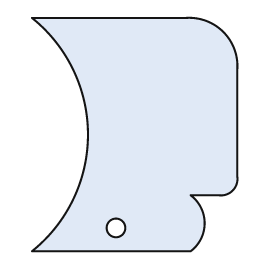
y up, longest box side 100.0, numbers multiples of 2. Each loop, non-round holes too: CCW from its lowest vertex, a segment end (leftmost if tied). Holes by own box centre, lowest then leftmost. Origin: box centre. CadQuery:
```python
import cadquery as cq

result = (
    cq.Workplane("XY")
    .moveTo(-44.0, -50.0)
    .lineTo(24.0, -50.0)
    .threePointArc((30.0, -38.0), (24.0, -26.0))
    .lineTo(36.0, -26.0)
    .threePointArc((42.0, -24.0), (44.0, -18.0))
    .lineTo(44.0, 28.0)
    .threePointArc((38.0, 44.0), (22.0, 50.0))
    .lineTo(-44.0, 50.0)
    .threePointArc((-20.0, 0.0), (-44.0, -50.0))
    .close()
    .moveTo(-8.0, -40.0)
    .circle(4.0)
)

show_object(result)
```